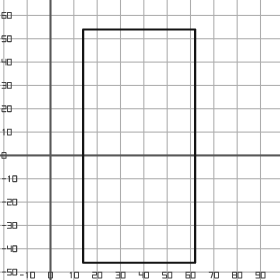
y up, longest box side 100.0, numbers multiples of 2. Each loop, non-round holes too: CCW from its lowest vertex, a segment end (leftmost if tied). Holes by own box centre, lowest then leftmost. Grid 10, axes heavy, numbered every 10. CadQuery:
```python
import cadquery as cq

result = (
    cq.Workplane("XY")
    .moveTo(14.0, -46.0)
    .lineTo(62.0, -46.0)
    .lineTo(62.0, 54.0)
    .lineTo(14.0, 54.0)
    .close()
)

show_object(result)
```